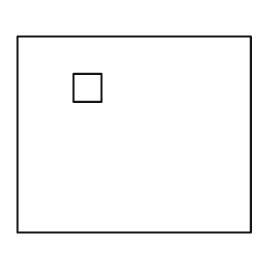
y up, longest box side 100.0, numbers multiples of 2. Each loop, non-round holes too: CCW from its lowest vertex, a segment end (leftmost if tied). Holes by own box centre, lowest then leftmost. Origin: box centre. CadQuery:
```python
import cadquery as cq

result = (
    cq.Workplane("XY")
    .moveTo(-50.0, -42.0)
    .lineTo(50.0, -42.0)
    .lineTo(50.0, 42.0)
    .lineTo(-50.0, 42.0)
    .close()
    .moveTo(-26.0, 14.0)
    .lineTo(-14.0, 14.0)
    .lineTo(-14.0, 26.0)
    .lineTo(-26.0, 26.0)
    .close()
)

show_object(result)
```